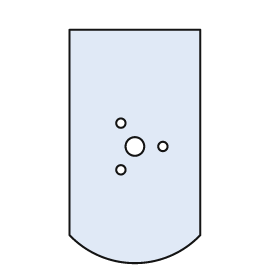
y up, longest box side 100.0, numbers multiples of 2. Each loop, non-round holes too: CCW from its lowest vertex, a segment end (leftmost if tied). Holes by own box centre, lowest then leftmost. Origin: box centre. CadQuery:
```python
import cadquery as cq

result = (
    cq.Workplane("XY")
    .moveTo(-28.0, -38.0)
    .threePointArc((0.0, -50.0), (28.0, -38.0))
    .lineTo(28.0, 50.0)
    .lineTo(-28.0, 50.0)
    .close()
    .moveTo(-6.0, -10.0)
    .circle(2.0)
    .moveTo(0.0, 0.0)
    .circle(4.0)
    .moveTo(12.0, 0.0)
    .circle(2.0)
    .moveTo(-6.0, 10.0)
    .circle(2.0)
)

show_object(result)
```